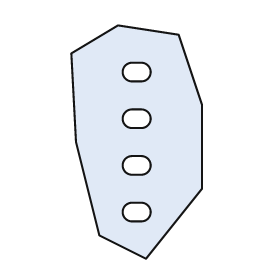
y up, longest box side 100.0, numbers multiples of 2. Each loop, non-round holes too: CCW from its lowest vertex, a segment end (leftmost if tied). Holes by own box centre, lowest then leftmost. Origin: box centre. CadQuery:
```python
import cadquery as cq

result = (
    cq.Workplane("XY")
    .moveTo(4.0, -50.0)
    .lineTo(28.0, -20.0)
    .lineTo(28.0, 16.0)
    .lineTo(18.0, 46.0)
    .lineTo(-8.0, 50.0)
    .lineTo(-28.0, 38.0)
    .lineTo(-26.0, 0.0)
    .lineTo(-16.0, -40.0)
    .close()
    .moveTo(-2.0, -34.0)
    .lineTo(2.0, -34.0)
    .threePointArc((6.0, -30.0), (2.0, -26.0))
    .lineTo(-2.0, -26.0)
    .threePointArc((-6.0, -30.0), (-2.0, -34.0))
    .close()
    .moveTo(-2.0, -14.0)
    .lineTo(2.0, -14.0)
    .threePointArc((6.0, -10.0), (2.0, -6.0))
    .lineTo(-2.0, -6.0)
    .threePointArc((-6.0, -10.0), (-2.0, -14.0))
    .close()
    .moveTo(-2.0, 6.0)
    .lineTo(2.0, 6.0)
    .threePointArc((6.0, 10.0), (2.0, 14.0))
    .lineTo(-2.0, 14.0)
    .threePointArc((-6.0, 10.0), (-2.0, 6.0))
    .close()
    .moveTo(-2.0, 26.0)
    .lineTo(2.0, 26.0)
    .threePointArc((6.0, 30.0), (2.0, 34.0))
    .lineTo(-2.0, 34.0)
    .threePointArc((-6.0, 30.0), (-2.0, 26.0))
    .close()
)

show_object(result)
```